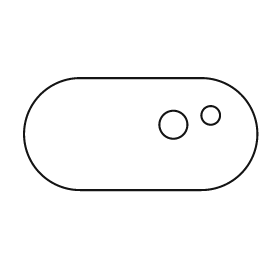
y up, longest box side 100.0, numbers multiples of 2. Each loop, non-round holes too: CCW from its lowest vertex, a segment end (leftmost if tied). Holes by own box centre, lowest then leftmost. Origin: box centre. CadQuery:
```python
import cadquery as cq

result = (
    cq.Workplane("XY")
    .moveTo(-26.0, -24.0)
    .lineTo(26.0, -24.0)
    .threePointArc((50.0, 0.0), (26.0, 24.0))
    .lineTo(-26.0, 24.0)
    .threePointArc((-50.0, 0.0), (-26.0, -24.0))
    .close()
    .moveTo(14.0, 4.0)
    .circle(6.0)
    .moveTo(30.0, 8.0)
    .circle(4.0)
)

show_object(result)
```